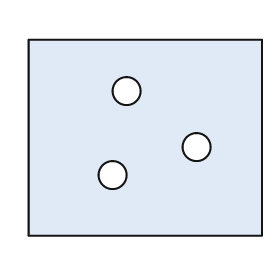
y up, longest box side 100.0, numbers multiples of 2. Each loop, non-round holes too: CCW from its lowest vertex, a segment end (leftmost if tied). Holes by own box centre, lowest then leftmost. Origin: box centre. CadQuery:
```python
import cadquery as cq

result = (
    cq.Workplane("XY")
    .moveTo(-50.0, -42.0)
    .lineTo(50.0, -42.0)
    .lineTo(50.0, 42.0)
    .lineTo(-50.0, 42.0)
    .close()
    .moveTo(-14.0, -16.0)
    .circle(6.0)
    .moveTo(22.0, -4.0)
    .circle(6.0)
    .moveTo(-8.0, 20.0)
    .circle(6.0)
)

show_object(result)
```